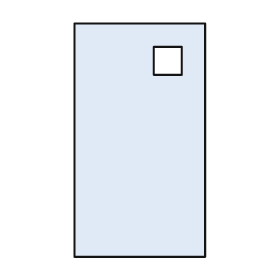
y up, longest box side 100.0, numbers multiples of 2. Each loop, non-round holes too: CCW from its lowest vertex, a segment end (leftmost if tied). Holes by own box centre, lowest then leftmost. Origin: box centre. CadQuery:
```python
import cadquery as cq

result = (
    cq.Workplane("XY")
    .moveTo(-28.0, -50.0)
    .lineTo(28.0, -50.0)
    .lineTo(28.0, 50.0)
    .lineTo(-28.0, 50.0)
    .close()
    .moveTo(6.0, 28.0)
    .lineTo(18.0, 28.0)
    .lineTo(18.0, 40.0)
    .lineTo(6.0, 40.0)
    .close()
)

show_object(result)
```